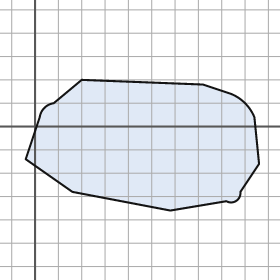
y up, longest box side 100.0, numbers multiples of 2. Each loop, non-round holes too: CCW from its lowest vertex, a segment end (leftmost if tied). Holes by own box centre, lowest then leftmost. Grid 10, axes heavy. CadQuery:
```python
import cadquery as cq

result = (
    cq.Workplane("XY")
    .moveTo(58.0, -36.0)
    .lineTo(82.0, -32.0)
    .threePointArc((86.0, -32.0), (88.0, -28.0))
    .lineTo(96.0, -16.0)
    .lineTo(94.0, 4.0)
    .threePointArc((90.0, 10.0), (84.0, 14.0))
    .lineTo(72.0, 18.0)
    .lineTo(20.0, 20.0)
    .lineTo(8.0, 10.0)
    .threePointArc((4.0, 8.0), (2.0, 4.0))
    .lineTo(-4.0, -14.0)
    .lineTo(16.0, -28.0)
    .close()
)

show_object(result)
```